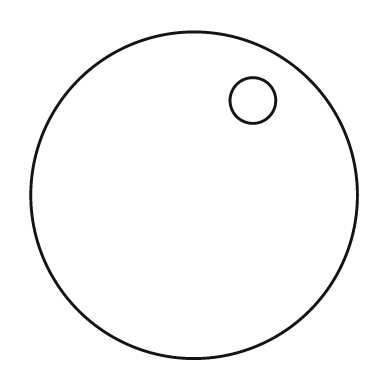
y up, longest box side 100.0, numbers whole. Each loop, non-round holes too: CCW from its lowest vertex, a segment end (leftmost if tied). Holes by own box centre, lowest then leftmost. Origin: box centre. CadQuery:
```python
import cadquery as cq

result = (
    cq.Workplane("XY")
    .moveTo(0.0, 0.0)
    .circle(50.0)
    .moveTo(18.0, 29.0)
    .circle(7.0)
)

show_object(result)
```